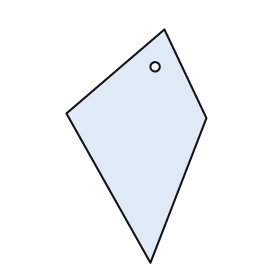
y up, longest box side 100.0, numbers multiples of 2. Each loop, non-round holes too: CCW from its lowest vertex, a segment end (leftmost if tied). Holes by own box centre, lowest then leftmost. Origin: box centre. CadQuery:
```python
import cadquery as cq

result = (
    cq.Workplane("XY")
    .moveTo(6.0, -50.0)
    .lineTo(30.0, 12.0)
    .lineTo(12.0, 50.0)
    .lineTo(-30.0, 14.0)
    .close()
    .moveTo(8.0, 34.0)
    .circle(2.0)
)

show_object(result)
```